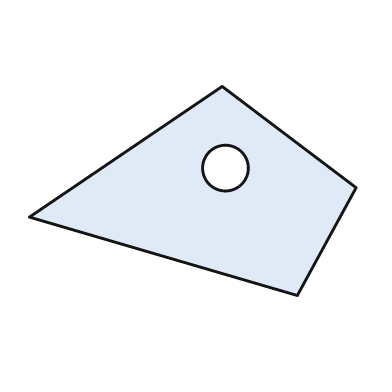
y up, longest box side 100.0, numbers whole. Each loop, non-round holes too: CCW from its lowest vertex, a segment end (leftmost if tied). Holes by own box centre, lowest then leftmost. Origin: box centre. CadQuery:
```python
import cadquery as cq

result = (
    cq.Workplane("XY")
    .moveTo(32.0, -32.0)
    .lineTo(50.0, 1.0)
    .lineTo(9.0, 32.0)
    .lineTo(-50.0, -8.0)
    .close()
    .moveTo(10.0, 7.0)
    .circle(7.0)
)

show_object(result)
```